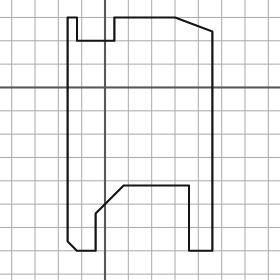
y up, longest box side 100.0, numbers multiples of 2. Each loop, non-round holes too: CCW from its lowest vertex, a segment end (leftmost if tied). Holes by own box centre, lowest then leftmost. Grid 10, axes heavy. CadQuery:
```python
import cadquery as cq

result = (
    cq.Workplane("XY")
    .moveTo(-12.0, -70.0)
    .lineTo(-4.0, -70.0)
    .lineTo(-4.0, -54.0)
    .lineTo(8.0, -42.0)
    .lineTo(36.0, -42.0)
    .lineTo(36.0, -70.0)
    .lineTo(46.0, -70.0)
    .lineTo(46.0, 24.0)
    .lineTo(30.0, 30.0)
    .lineTo(4.0, 30.0)
    .lineTo(4.0, 20.0)
    .lineTo(-12.0, 20.0)
    .lineTo(-12.0, 30.0)
    .lineTo(-16.0, 30.0)
    .lineTo(-16.0, -66.0)
    .close()
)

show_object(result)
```